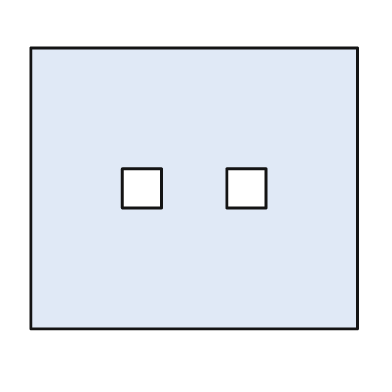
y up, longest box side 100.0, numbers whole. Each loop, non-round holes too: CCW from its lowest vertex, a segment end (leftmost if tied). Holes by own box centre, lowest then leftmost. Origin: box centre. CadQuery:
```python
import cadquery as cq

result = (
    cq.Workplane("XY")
    .moveTo(-50.0, -43.0)
    .lineTo(50.0, -43.0)
    .lineTo(50.0, 43.0)
    .lineTo(-50.0, 43.0)
    .close()
    .moveTo(-22.0, -6.0)
    .lineTo(-10.0, -6.0)
    .lineTo(-10.0, 6.0)
    .lineTo(-22.0, 6.0)
    .close()
    .moveTo(10.0, -6.0)
    .lineTo(22.0, -6.0)
    .lineTo(22.0, 6.0)
    .lineTo(10.0, 6.0)
    .close()
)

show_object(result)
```